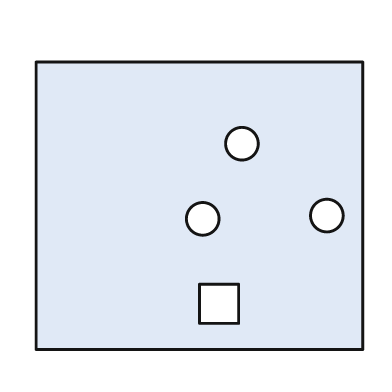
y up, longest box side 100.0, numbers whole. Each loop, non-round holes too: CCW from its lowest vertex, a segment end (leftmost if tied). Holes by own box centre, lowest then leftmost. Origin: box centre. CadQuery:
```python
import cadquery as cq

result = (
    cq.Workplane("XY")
    .moveTo(-50.0, -44.0)
    .lineTo(50.0, -44.0)
    .lineTo(50.0, 44.0)
    .lineTo(-50.0, 44.0)
    .close()
    .moveTo(0.0, -36.0)
    .lineTo(12.0, -36.0)
    .lineTo(12.0, -24.0)
    .lineTo(0.0, -24.0)
    .close()
    .moveTo(1.0, -4.0)
    .circle(5.0)
    .moveTo(39.0, -3.0)
    .circle(5.0)
    .moveTo(13.0, 19.0)
    .circle(5.0)
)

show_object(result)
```